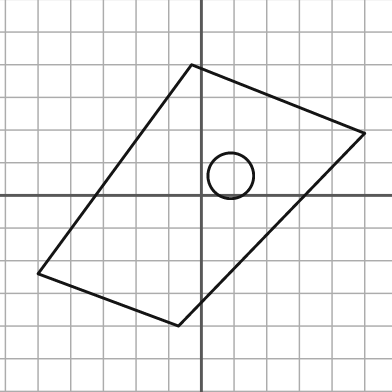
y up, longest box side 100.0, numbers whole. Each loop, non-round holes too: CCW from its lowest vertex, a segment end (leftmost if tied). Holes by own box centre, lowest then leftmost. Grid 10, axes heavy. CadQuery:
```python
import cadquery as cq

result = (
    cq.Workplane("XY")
    .moveTo(-7.0, -40.0)
    .lineTo(50.0, 19.0)
    .lineTo(-3.0, 40.0)
    .lineTo(-50.0, -24.0)
    .close()
    .moveTo(9.0, 6.0)
    .circle(7.0)
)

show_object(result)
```